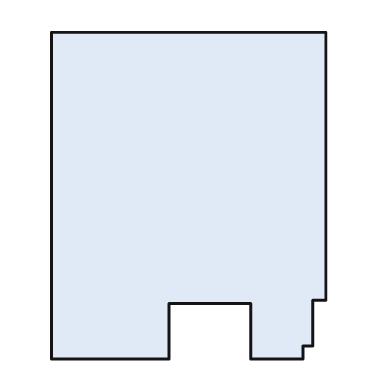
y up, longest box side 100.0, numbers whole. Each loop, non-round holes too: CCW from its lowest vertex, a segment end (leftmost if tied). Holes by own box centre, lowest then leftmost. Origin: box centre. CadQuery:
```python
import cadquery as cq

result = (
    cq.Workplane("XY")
    .moveTo(-42.0, -50.0)
    .lineTo(-6.0, -50.0)
    .lineTo(-6.0, -33.0)
    .lineTo(19.0, -33.0)
    .lineTo(19.0, -50.0)
    .lineTo(35.0, -50.0)
    .lineTo(35.0, -46.0)
    .lineTo(38.0, -46.0)
    .lineTo(38.0, -32.0)
    .lineTo(42.0, -32.0)
    .lineTo(42.0, 50.0)
    .lineTo(-42.0, 50.0)
    .close()
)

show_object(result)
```